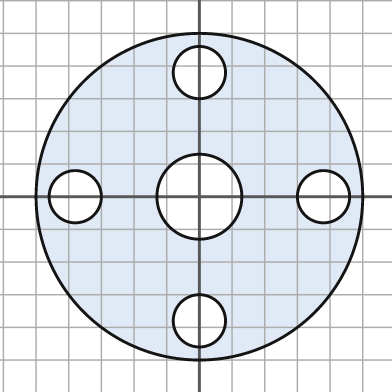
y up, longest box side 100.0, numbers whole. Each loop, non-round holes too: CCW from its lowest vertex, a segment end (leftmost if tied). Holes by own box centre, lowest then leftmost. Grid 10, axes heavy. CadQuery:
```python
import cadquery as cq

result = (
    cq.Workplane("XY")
    .moveTo(0.0, 0.0)
    .circle(50.0)
    .moveTo(0.0, -38.0)
    .circle(8.0)
    .moveTo(-38.0, 0.0)
    .circle(8.0)
    .moveTo(0.0, 0.0)
    .circle(13.0)
    .moveTo(38.0, 0.0)
    .circle(8.0)
    .moveTo(0.0, 38.0)
    .circle(8.0)
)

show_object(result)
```